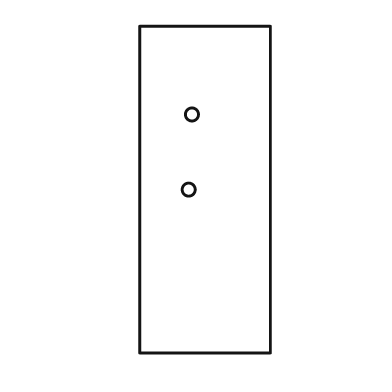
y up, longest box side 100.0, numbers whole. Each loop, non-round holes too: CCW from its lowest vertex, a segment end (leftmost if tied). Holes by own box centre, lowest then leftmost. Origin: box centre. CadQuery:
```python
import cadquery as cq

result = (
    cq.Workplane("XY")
    .moveTo(-20.0, -50.0)
    .lineTo(20.0, -50.0)
    .lineTo(20.0, 50.0)
    .lineTo(-20.0, 50.0)
    .close()
    .moveTo(-5.0, 0.0)
    .circle(2.0)
    .moveTo(-4.0, 23.0)
    .circle(2.0)
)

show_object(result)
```